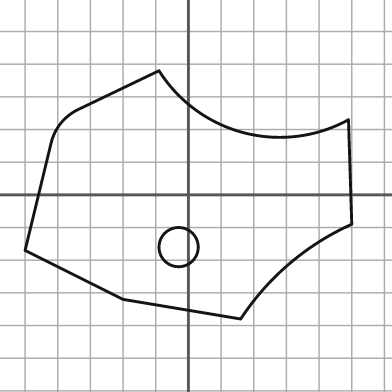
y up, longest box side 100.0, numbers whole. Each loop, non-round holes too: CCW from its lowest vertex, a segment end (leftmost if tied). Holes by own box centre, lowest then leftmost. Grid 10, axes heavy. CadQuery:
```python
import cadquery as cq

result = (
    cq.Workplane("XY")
    .moveTo(16.0, -38.0)
    .threePointArc((31.0, -21.0), (50.0, -9.0))
    .lineTo(49.0, 23.0)
    .threePointArc((17.0, 19.0), (-9.0, 38.0))
    .lineTo(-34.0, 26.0)
    .threePointArc((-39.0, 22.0), (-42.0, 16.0))
    .lineTo(-50.0, -17.0)
    .lineTo(-20.0, -32.0)
    .close()
    .moveTo(-3.0, -16.0)
    .circle(6.0)
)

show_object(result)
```